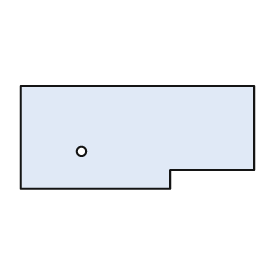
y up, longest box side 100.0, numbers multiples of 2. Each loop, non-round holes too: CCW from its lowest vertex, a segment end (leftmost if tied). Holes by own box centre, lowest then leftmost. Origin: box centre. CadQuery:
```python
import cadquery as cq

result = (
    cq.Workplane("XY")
    .moveTo(-50.0, -22.0)
    .lineTo(14.0, -22.0)
    .lineTo(14.0, -14.0)
    .lineTo(50.0, -14.0)
    .lineTo(50.0, 22.0)
    .lineTo(-50.0, 22.0)
    .close()
    .moveTo(-24.0, -6.0)
    .circle(2.0)
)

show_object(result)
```